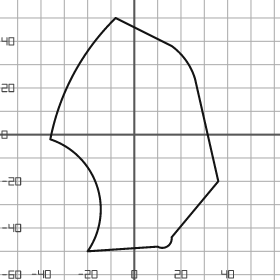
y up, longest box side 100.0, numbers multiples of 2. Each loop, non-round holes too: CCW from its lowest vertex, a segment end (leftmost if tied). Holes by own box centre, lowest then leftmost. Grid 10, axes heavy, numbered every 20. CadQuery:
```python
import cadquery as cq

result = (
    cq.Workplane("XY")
    .moveTo(-20.0, -50.0)
    .lineTo(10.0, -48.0)
    .threePointArc((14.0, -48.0), (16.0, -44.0))
    .lineTo(36.0, -20.0)
    .lineTo(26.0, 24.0)
    .threePointArc((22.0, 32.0), (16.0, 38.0))
    .lineTo(-8.0, 50.0)
    .threePointArc((-26.0, 26.0), (-36.0, -2.0))
    .threePointArc((-16.0, -22.0), (-20.0, -50.0))
    .close()
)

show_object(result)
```